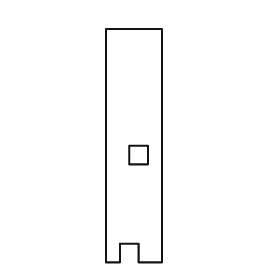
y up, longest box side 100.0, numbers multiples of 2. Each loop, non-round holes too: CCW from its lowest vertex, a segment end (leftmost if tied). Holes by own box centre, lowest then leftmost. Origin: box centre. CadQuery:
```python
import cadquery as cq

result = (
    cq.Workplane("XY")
    .moveTo(-12.0, -50.0)
    .lineTo(-6.0, -50.0)
    .lineTo(-6.0, -42.0)
    .lineTo(2.0, -42.0)
    .lineTo(2.0, -50.0)
    .lineTo(12.0, -50.0)
    .lineTo(12.0, 50.0)
    .lineTo(-12.0, 50.0)
    .close()
    .moveTo(-2.0, -8.0)
    .lineTo(6.0, -8.0)
    .lineTo(6.0, 0.0)
    .lineTo(-2.0, 0.0)
    .close()
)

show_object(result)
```